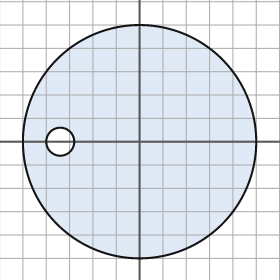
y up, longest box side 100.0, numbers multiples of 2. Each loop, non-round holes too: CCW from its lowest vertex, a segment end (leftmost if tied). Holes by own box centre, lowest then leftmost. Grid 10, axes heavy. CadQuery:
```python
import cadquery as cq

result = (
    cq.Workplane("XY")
    .moveTo(0.0, 0.0)
    .circle(50.0)
    .moveTo(-34.0, 0.0)
    .circle(6.0)
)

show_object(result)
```